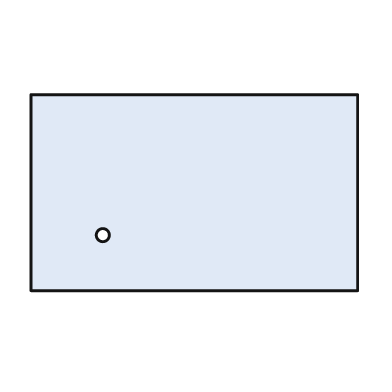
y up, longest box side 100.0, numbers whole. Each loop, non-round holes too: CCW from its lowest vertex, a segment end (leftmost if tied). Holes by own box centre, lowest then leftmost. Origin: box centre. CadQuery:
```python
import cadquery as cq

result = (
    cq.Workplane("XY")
    .moveTo(-50.0, -30.0)
    .lineTo(50.0, -30.0)
    .lineTo(50.0, 30.0)
    .lineTo(-50.0, 30.0)
    .close()
    .moveTo(-28.0, -13.0)
    .circle(2.0)
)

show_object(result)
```